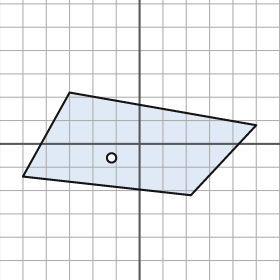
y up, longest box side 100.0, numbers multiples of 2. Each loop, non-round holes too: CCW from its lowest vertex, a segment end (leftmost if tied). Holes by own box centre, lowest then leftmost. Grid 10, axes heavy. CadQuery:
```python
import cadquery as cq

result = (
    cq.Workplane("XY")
    .moveTo(22.0, -22.0)
    .lineTo(50.0, 8.0)
    .lineTo(-30.0, 22.0)
    .lineTo(-50.0, -14.0)
    .close()
    .moveTo(-12.0, -6.0)
    .circle(2.0)
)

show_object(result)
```